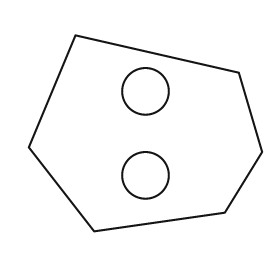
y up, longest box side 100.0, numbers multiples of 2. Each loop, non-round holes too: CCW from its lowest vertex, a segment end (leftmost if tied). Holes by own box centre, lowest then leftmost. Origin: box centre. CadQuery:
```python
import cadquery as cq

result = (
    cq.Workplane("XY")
    .moveTo(-22.0, -42.0)
    .lineTo(34.0, -34.0)
    .lineTo(50.0, -8.0)
    .lineTo(40.0, 26.0)
    .lineTo(-30.0, 42.0)
    .lineTo(-50.0, -6.0)
    .close()
    .moveTo(0.0, -18.0)
    .circle(10.0)
    .moveTo(0.0, 18.0)
    .circle(10.0)
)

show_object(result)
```